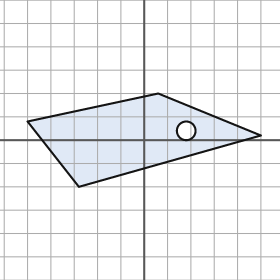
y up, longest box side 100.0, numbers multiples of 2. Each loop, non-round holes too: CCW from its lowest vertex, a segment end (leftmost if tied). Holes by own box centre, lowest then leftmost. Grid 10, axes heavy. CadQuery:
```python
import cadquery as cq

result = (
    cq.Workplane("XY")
    .moveTo(-28.0, -20.0)
    .lineTo(50.0, 2.0)
    .lineTo(6.0, 20.0)
    .lineTo(-50.0, 8.0)
    .close()
    .moveTo(18.0, 4.0)
    .circle(4.0)
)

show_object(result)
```